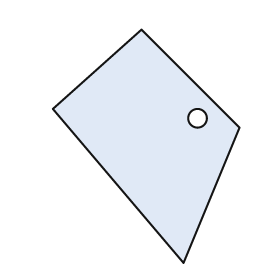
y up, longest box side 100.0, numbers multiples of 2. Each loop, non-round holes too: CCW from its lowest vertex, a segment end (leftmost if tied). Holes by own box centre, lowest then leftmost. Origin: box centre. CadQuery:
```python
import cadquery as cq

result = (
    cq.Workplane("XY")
    .moveTo(16.0, -50.0)
    .lineTo(40.0, 8.0)
    .lineTo(-2.0, 50.0)
    .lineTo(-40.0, 16.0)
    .close()
    .moveTo(22.0, 12.0)
    .circle(4.0)
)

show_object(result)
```